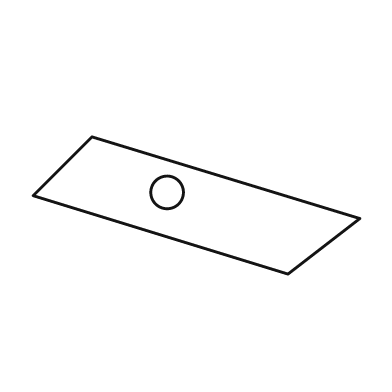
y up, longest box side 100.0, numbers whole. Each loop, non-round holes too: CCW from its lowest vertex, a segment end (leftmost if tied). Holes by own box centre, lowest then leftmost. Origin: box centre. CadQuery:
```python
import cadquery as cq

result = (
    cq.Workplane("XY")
    .moveTo(28.0, -21.0)
    .lineTo(50.0, -4.0)
    .lineTo(-32.0, 21.0)
    .lineTo(-50.0, 3.0)
    .close()
    .moveTo(-9.0, 4.0)
    .circle(5.0)
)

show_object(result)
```